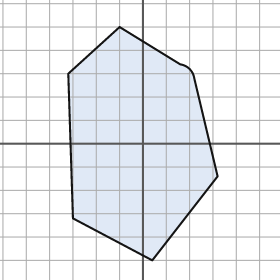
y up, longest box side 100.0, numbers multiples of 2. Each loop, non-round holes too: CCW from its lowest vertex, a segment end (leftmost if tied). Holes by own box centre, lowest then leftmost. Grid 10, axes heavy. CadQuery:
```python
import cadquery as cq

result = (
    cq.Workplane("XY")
    .moveTo(4.0, -50.0)
    .lineTo(32.0, -14.0)
    .lineTo(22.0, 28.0)
    .threePointArc((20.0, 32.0), (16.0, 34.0))
    .lineTo(-10.0, 50.0)
    .lineTo(-32.0, 30.0)
    .lineTo(-30.0, -32.0)
    .close()
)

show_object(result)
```